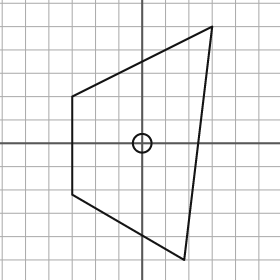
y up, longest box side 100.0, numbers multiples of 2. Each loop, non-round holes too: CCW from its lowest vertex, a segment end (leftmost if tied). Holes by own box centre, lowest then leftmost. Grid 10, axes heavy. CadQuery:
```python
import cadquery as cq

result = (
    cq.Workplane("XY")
    .moveTo(18.0, -50.0)
    .lineTo(30.0, 50.0)
    .lineTo(-30.0, 20.0)
    .lineTo(-30.0, -22.0)
    .close()
    .moveTo(0.0, 0.0)
    .circle(4.0)
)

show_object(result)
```